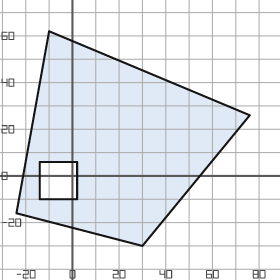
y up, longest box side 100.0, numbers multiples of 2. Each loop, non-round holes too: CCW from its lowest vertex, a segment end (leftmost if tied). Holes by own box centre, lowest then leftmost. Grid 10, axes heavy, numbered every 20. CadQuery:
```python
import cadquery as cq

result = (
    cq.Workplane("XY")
    .moveTo(30.0, -30.0)
    .lineTo(76.0, 26.0)
    .lineTo(-10.0, 62.0)
    .lineTo(-24.0, -16.0)
    .close()
    .moveTo(-14.0, -10.0)
    .lineTo(2.0, -10.0)
    .lineTo(2.0, 6.0)
    .lineTo(-14.0, 6.0)
    .close()
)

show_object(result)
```